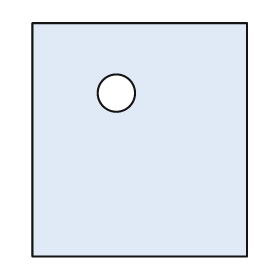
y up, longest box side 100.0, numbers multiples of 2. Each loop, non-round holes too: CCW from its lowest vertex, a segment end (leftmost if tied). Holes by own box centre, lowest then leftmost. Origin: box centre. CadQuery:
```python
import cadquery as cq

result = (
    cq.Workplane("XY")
    .moveTo(-46.0, -50.0)
    .lineTo(46.0, -50.0)
    .lineTo(46.0, 50.0)
    .lineTo(-46.0, 50.0)
    .close()
    .moveTo(-10.0, 20.0)
    .circle(8.0)
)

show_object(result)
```